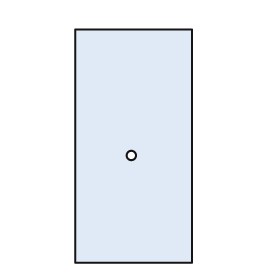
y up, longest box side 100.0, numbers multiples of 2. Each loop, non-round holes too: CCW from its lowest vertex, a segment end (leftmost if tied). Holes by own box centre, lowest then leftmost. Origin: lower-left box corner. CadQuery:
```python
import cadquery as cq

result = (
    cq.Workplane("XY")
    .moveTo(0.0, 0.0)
    .lineTo(50.0, 0.0)
    .lineTo(50.0, 100.0)
    .lineTo(0.0, 100.0)
    .close()
    .moveTo(24.0, 46.0)
    .circle(2.0)
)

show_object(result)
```